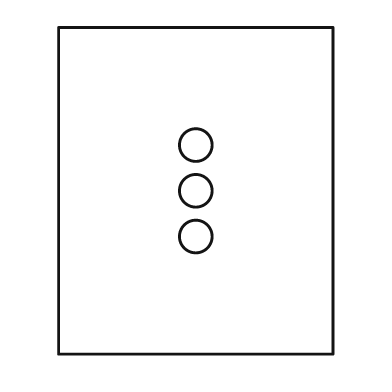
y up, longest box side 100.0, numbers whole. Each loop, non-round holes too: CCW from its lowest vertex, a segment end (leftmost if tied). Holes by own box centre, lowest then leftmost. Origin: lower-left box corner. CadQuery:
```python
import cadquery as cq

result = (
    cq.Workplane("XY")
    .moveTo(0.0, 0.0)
    .lineTo(84.0, 0.0)
    .lineTo(84.0, 100.0)
    .lineTo(0.0, 100.0)
    .close()
    .moveTo(42.0, 36.0)
    .circle(5.0)
    .moveTo(42.0, 50.0)
    .circle(5.0)
    .moveTo(42.0, 64.0)
    .circle(5.0)
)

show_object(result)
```